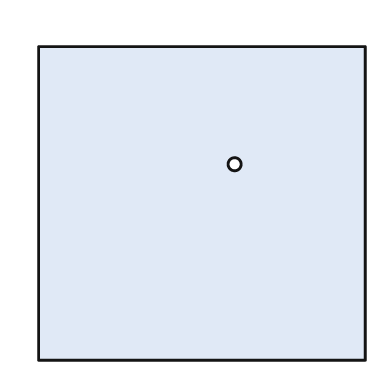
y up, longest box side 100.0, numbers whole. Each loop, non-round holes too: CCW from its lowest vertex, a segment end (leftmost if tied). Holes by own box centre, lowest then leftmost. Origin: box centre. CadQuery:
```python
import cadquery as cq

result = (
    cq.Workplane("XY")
    .moveTo(-50.0, -48.0)
    .lineTo(50.0, -48.0)
    .lineTo(50.0, 48.0)
    .lineTo(-50.0, 48.0)
    .close()
    .moveTo(10.0, 12.0)
    .circle(2.0)
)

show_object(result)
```